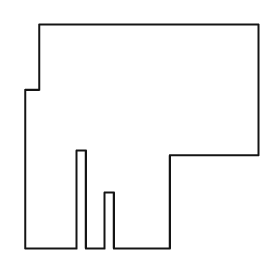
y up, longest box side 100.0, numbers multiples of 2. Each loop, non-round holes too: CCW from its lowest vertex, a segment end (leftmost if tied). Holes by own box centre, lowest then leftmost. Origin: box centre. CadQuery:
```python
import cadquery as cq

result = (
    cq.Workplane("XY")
    .moveTo(-50.0, -48.0)
    .lineTo(-28.0, -48.0)
    .lineTo(-28.0, -6.0)
    .lineTo(-24.0, -6.0)
    .lineTo(-24.0, -48.0)
    .lineTo(-16.0, -48.0)
    .lineTo(-16.0, -24.0)
    .lineTo(-12.0, -24.0)
    .lineTo(-12.0, -48.0)
    .lineTo(12.0, -48.0)
    .lineTo(12.0, -8.0)
    .lineTo(50.0, -8.0)
    .lineTo(50.0, 48.0)
    .lineTo(-44.0, 48.0)
    .lineTo(-44.0, 20.0)
    .lineTo(-50.0, 20.0)
    .close()
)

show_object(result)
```